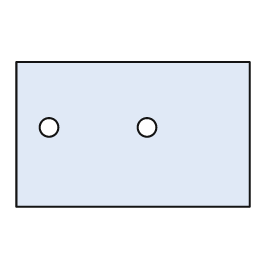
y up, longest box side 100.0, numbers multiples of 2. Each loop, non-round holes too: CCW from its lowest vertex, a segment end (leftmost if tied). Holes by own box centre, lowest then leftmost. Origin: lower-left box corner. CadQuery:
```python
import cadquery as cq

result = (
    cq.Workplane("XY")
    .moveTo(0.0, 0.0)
    .lineTo(100.0, 0.0)
    .lineTo(100.0, 62.0)
    .lineTo(0.0, 62.0)
    .close()
    .moveTo(14.0, 34.0)
    .circle(4.0)
    .moveTo(56.0, 34.0)
    .circle(4.0)
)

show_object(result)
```